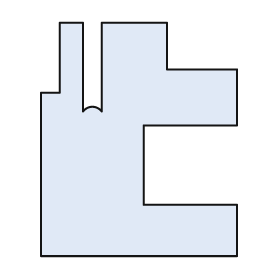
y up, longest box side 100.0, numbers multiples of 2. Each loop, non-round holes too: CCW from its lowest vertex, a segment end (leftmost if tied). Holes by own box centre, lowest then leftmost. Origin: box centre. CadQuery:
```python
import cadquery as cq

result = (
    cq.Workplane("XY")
    .moveTo(-42.0, -50.0)
    .lineTo(42.0, -50.0)
    .lineTo(42.0, -28.0)
    .lineTo(2.0, -28.0)
    .lineTo(2.0, 6.0)
    .lineTo(42.0, 6.0)
    .lineTo(42.0, 30.0)
    .lineTo(12.0, 30.0)
    .lineTo(12.0, 50.0)
    .lineTo(-16.0, 50.0)
    .lineTo(-16.0, 12.0)
    .threePointArc((-20.0, 14.0), (-24.0, 12.0))
    .lineTo(-24.0, 50.0)
    .lineTo(-34.0, 50.0)
    .lineTo(-34.0, 20.0)
    .lineTo(-42.0, 20.0)
    .close()
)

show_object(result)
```